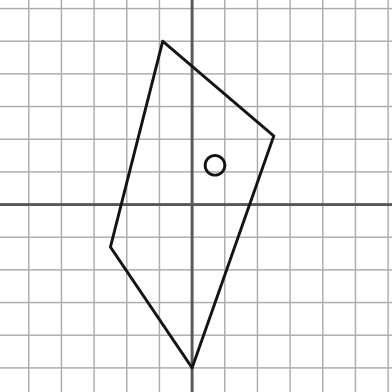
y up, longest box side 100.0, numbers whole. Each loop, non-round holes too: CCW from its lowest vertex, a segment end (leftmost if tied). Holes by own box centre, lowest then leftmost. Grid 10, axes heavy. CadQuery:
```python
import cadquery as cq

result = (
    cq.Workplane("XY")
    .moveTo(0.0, -50.0)
    .lineTo(25.0, 21.0)
    .lineTo(-9.0, 50.0)
    .lineTo(-25.0, -13.0)
    .close()
    .moveTo(7.0, 12.0)
    .circle(3.0)
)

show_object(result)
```